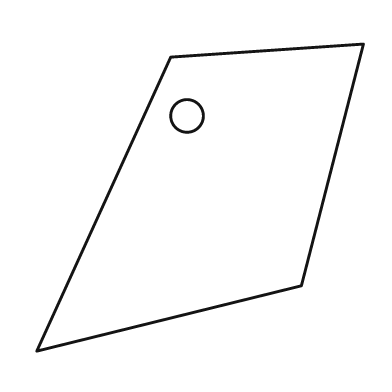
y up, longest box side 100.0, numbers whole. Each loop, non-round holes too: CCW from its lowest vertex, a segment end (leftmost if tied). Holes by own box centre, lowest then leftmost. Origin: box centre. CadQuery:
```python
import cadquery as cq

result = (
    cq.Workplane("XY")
    .moveTo(-50.0, -47.0)
    .lineTo(31.0, -27.0)
    .lineTo(50.0, 47.0)
    .lineTo(-9.0, 43.0)
    .close()
    .moveTo(-4.0, 25.0)
    .circle(5.0)
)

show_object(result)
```